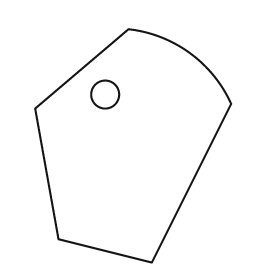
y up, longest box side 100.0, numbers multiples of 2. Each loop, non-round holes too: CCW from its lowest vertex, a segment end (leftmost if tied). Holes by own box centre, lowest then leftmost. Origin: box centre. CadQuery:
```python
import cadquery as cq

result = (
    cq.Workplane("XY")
    .moveTo(8.0, -50.0)
    .lineTo(42.0, 18.0)
    .threePointArc((24.0, 40.0), (-2.0, 50.0))
    .lineTo(-42.0, 16.0)
    .lineTo(-32.0, -40.0)
    .close()
    .moveTo(-12.0, 22.0)
    .circle(6.0)
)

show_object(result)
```